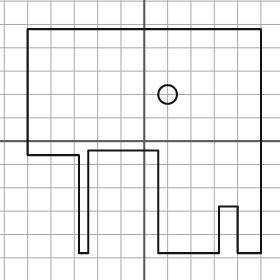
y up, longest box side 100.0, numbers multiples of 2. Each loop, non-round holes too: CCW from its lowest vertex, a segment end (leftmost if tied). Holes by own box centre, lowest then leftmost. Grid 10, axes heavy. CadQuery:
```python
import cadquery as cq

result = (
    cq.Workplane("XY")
    .moveTo(-28.0, -48.0)
    .lineTo(-24.0, -48.0)
    .lineTo(-24.0, -4.0)
    .lineTo(6.0, -4.0)
    .lineTo(6.0, -48.0)
    .lineTo(32.0, -48.0)
    .lineTo(32.0, -28.0)
    .lineTo(40.0, -28.0)
    .lineTo(40.0, -48.0)
    .lineTo(50.0, -48.0)
    .lineTo(50.0, 48.0)
    .lineTo(-50.0, 48.0)
    .lineTo(-50.0, -6.0)
    .lineTo(-28.0, -6.0)
    .close()
    .moveTo(10.0, 20.0)
    .circle(4.0)
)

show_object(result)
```